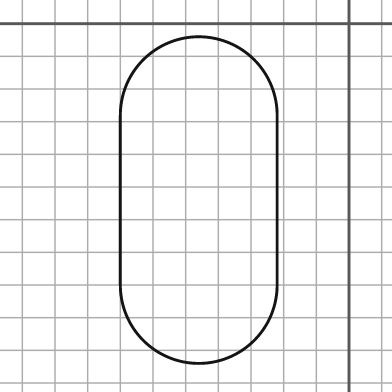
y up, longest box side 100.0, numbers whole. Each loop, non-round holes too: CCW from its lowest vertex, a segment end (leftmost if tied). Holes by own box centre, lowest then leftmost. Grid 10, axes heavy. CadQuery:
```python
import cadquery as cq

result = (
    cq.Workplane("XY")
    .moveTo(-70.0, -80.0)
    .threePointArc((-46.0, -104.0), (-22.0, -80.0))
    .lineTo(-22.0, -28.0)
    .threePointArc((-46.0, -4.0), (-70.0, -28.0))
    .close()
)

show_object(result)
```